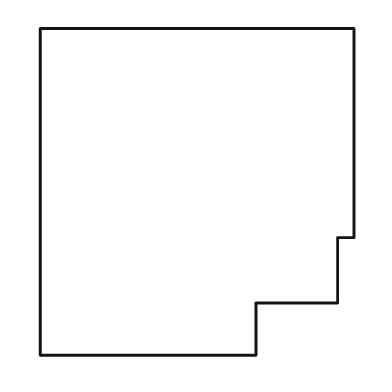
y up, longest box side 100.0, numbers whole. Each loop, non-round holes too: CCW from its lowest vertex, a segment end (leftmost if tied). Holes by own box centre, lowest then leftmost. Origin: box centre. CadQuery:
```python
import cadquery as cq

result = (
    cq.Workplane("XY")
    .moveTo(-48.0, -50.0)
    .lineTo(18.0, -50.0)
    .lineTo(18.0, -34.0)
    .lineTo(43.0, -34.0)
    .lineTo(43.0, -14.0)
    .lineTo(48.0, -14.0)
    .lineTo(48.0, 50.0)
    .lineTo(-48.0, 50.0)
    .close()
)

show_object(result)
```